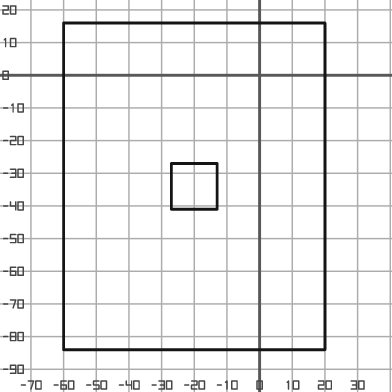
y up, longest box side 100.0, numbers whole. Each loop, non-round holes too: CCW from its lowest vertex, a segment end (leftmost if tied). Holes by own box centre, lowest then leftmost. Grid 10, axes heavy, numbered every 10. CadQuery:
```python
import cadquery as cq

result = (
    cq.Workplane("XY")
    .moveTo(-60.0, -84.0)
    .lineTo(20.0, -84.0)
    .lineTo(20.0, 16.0)
    .lineTo(-60.0, 16.0)
    .close()
    .moveTo(-27.0, -41.0)
    .lineTo(-13.0, -41.0)
    .lineTo(-13.0, -27.0)
    .lineTo(-27.0, -27.0)
    .close()
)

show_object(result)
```